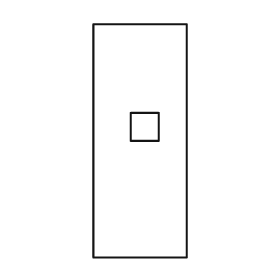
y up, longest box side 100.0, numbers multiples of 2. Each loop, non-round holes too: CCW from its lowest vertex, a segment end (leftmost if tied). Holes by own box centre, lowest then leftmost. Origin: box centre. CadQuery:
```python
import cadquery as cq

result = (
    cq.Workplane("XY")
    .moveTo(-20.0, -50.0)
    .lineTo(20.0, -50.0)
    .lineTo(20.0, 50.0)
    .lineTo(-20.0, 50.0)
    .close()
    .moveTo(-4.0, 0.0)
    .lineTo(8.0, 0.0)
    .lineTo(8.0, 12.0)
    .lineTo(-4.0, 12.0)
    .close()
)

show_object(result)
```